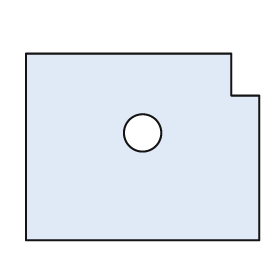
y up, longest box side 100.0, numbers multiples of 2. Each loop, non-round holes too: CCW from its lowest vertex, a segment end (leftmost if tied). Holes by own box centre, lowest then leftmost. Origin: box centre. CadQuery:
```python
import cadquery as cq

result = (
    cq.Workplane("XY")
    .moveTo(-50.0, -40.0)
    .lineTo(50.0, -40.0)
    .lineTo(50.0, 22.0)
    .lineTo(38.0, 22.0)
    .lineTo(38.0, 40.0)
    .lineTo(-50.0, 40.0)
    .close()
    .moveTo(0.0, 6.0)
    .circle(8.0)
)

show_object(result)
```